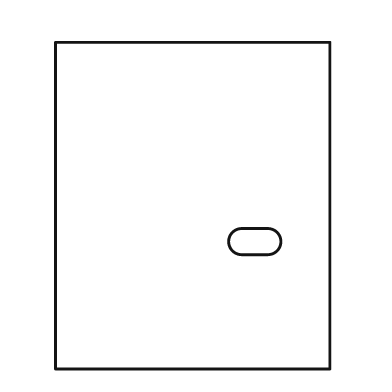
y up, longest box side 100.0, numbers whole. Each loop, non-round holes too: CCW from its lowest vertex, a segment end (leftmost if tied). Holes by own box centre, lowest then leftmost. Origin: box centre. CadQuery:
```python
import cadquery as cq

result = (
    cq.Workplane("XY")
    .moveTo(-42.0, -50.0)
    .lineTo(42.0, -50.0)
    .lineTo(42.0, 50.0)
    .lineTo(-42.0, 50.0)
    .close()
    .moveTo(15.0, -15.0)
    .lineTo(23.0, -15.0)
    .threePointArc((27.0, -11.0), (23.0, -7.0))
    .lineTo(15.0, -7.0)
    .threePointArc((11.0, -11.0), (15.0, -15.0))
    .close()
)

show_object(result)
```